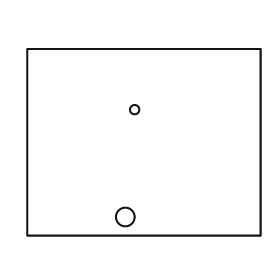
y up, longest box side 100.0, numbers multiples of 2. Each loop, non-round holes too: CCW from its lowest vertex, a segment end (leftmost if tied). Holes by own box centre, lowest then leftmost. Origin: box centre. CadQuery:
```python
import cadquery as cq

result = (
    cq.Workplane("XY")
    .moveTo(-50.0, -40.0)
    .lineTo(50.0, -40.0)
    .lineTo(50.0, 40.0)
    .lineTo(-50.0, 40.0)
    .close()
    .moveTo(-8.0, -32.0)
    .circle(4.0)
    .moveTo(-4.0, 14.0)
    .circle(2.0)
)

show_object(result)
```